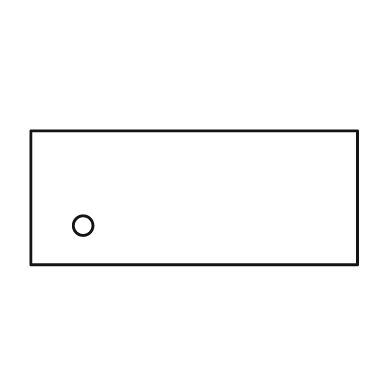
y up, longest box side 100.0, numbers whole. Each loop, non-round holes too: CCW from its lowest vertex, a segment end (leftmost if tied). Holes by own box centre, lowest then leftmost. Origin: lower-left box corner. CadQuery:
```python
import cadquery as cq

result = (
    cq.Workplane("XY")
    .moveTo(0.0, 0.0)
    .lineTo(100.0, 0.0)
    .lineTo(100.0, 41.0)
    .lineTo(0.0, 41.0)
    .close()
    .moveTo(16.0, 12.0)
    .circle(3.0)
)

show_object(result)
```